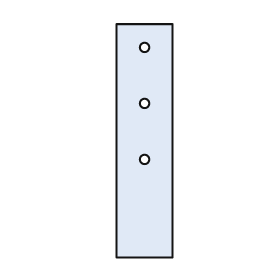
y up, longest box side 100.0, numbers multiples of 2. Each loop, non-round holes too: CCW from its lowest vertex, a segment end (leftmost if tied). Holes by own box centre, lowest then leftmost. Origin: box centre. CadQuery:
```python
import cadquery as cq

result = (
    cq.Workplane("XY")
    .moveTo(-12.0, -50.0)
    .lineTo(12.0, -50.0)
    .lineTo(12.0, 50.0)
    .lineTo(-12.0, 50.0)
    .close()
    .moveTo(0.0, -8.0)
    .circle(2.0)
    .moveTo(0.0, 16.0)
    .circle(2.0)
    .moveTo(0.0, 40.0)
    .circle(2.0)
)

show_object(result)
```